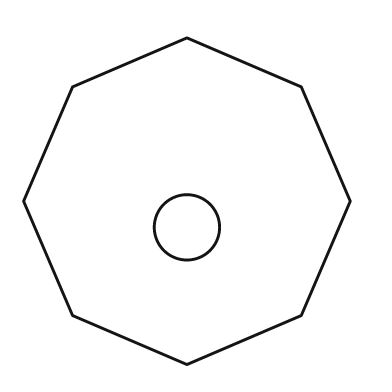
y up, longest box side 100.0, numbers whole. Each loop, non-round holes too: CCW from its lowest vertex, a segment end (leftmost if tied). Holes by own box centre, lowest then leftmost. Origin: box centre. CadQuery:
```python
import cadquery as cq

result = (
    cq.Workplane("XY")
    .moveTo(0.0, -50.0)
    .lineTo(35.0, -35.0)
    .lineTo(50.0, 0.0)
    .lineTo(35.0, 35.0)
    .lineTo(0.0, 50.0)
    .lineTo(-35.0, 35.0)
    .lineTo(-50.0, 0.0)
    .lineTo(-35.0, -35.0)
    .close()
    .moveTo(0.0, -8.0)
    .circle(10.0)
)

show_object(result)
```